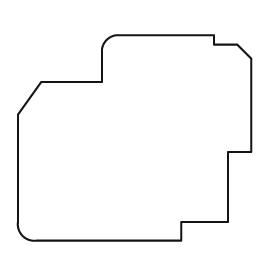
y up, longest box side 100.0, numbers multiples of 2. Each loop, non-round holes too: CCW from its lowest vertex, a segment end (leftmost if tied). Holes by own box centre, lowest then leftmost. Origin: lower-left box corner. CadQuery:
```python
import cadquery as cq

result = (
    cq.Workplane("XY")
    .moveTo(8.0, 0.0)
    .lineTo(70.0, 0.0)
    .lineTo(70.0, 8.0)
    .lineTo(90.0, 8.0)
    .lineTo(90.0, 38.0)
    .lineTo(100.0, 38.0)
    .lineTo(100.0, 78.0)
    .lineTo(94.0, 84.0)
    .lineTo(84.0, 84.0)
    .lineTo(84.0, 88.0)
    .lineTo(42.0, 88.0)
    .threePointArc((38.0, 86.0), (36.0, 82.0))
    .lineTo(36.0, 68.0)
    .lineTo(10.0, 68.0)
    .lineTo(0.0, 54.0)
    .lineTo(0.0, 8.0)
    .threePointArc((2.0, 2.0), (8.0, 0.0))
    .close()
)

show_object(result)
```